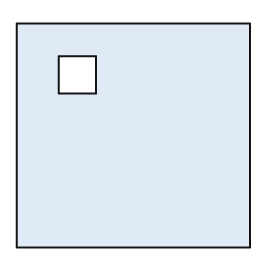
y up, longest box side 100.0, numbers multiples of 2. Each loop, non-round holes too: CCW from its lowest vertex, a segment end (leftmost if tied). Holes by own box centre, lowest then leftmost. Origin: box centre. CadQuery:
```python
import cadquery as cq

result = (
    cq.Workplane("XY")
    .moveTo(-50.0, -48.0)
    .lineTo(50.0, -48.0)
    .lineTo(50.0, 48.0)
    .lineTo(-50.0, 48.0)
    .close()
    .moveTo(-32.0, 18.0)
    .lineTo(-16.0, 18.0)
    .lineTo(-16.0, 34.0)
    .lineTo(-32.0, 34.0)
    .close()
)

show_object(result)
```